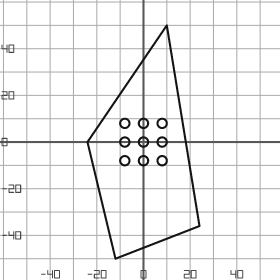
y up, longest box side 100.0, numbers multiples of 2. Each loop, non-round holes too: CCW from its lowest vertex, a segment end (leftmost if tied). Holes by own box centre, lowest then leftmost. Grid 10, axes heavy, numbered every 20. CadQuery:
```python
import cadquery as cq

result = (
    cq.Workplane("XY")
    .moveTo(-12.0, -50.0)
    .lineTo(24.0, -36.0)
    .lineTo(10.0, 50.0)
    .lineTo(-24.0, 0.0)
    .close()
    .moveTo(-8.0, -8.0)
    .circle(2.0)
    .moveTo(0.0, -8.0)
    .circle(2.0)
    .moveTo(8.0, -8.0)
    .circle(2.0)
    .moveTo(-8.0, 0.0)
    .circle(2.0)
    .moveTo(0.0, 0.0)
    .circle(2.0)
    .moveTo(8.0, 0.0)
    .circle(2.0)
    .moveTo(-8.0, 8.0)
    .circle(2.0)
    .moveTo(0.0, 8.0)
    .circle(2.0)
    .moveTo(8.0, 8.0)
    .circle(2.0)
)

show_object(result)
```